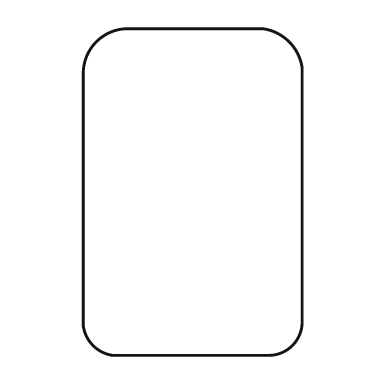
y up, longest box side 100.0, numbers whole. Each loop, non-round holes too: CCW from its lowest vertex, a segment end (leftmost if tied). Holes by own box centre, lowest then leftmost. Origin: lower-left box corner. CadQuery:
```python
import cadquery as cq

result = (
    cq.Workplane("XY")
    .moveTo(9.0, 0.0)
    .lineTo(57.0, 0.0)
    .threePointArc((64.0, 3.0), (67.0, 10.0))
    .lineTo(67.0, 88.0)
    .threePointArc((63.0, 96.0), (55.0, 100.0))
    .lineTo(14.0, 100.0)
    .threePointArc((4.0, 96.0), (0.0, 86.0))
    .lineTo(0.0, 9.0)
    .threePointArc((3.0, 3.0), (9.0, 0.0))
    .close()
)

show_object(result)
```